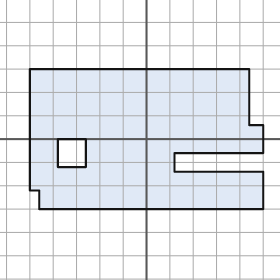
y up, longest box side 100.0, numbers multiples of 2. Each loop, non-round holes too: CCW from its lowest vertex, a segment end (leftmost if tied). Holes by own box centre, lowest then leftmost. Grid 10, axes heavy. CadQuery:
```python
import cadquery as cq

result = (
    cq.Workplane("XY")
    .moveTo(-46.0, -30.0)
    .lineTo(50.0, -30.0)
    .lineTo(50.0, -14.0)
    .lineTo(12.0, -14.0)
    .lineTo(12.0, -6.0)
    .lineTo(50.0, -6.0)
    .lineTo(50.0, 6.0)
    .lineTo(44.0, 6.0)
    .lineTo(44.0, 30.0)
    .lineTo(-50.0, 30.0)
    .lineTo(-50.0, -22.0)
    .lineTo(-46.0, -22.0)
    .close()
    .moveTo(-38.0, -12.0)
    .lineTo(-26.0, -12.0)
    .lineTo(-26.0, 0.0)
    .lineTo(-38.0, 0.0)
    .close()
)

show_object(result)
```